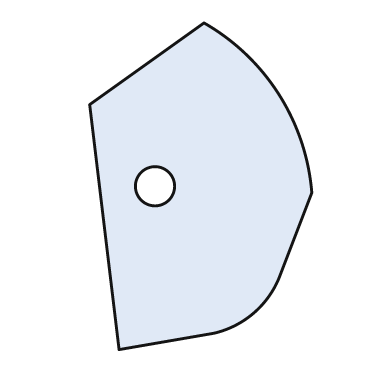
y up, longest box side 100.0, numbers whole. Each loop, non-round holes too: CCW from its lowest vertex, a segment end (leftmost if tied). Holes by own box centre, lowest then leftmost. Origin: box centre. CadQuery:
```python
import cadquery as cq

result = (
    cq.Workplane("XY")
    .moveTo(-25.0, -50.0)
    .lineTo(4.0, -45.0)
    .threePointArc((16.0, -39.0), (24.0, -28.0))
    .lineTo(34.0, -2.0)
    .threePointArc((24.0, 28.0), (1.0, 50.0))
    .lineTo(-34.0, 25.0)
    .close()
    .moveTo(-14.0, 0.0)
    .circle(6.0)
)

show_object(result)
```